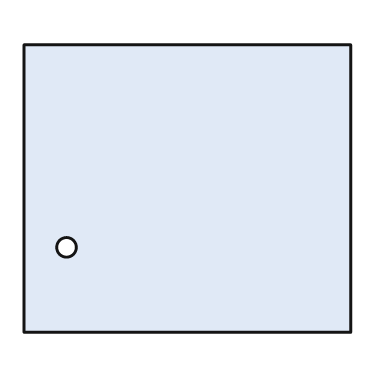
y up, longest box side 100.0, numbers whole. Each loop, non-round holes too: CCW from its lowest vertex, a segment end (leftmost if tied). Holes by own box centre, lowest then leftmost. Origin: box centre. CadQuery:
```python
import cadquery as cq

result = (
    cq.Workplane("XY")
    .moveTo(-50.0, -44.0)
    .lineTo(50.0, -44.0)
    .lineTo(50.0, 44.0)
    .lineTo(-50.0, 44.0)
    .close()
    .moveTo(-37.0, -18.0)
    .circle(3.0)
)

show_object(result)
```